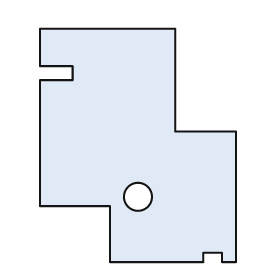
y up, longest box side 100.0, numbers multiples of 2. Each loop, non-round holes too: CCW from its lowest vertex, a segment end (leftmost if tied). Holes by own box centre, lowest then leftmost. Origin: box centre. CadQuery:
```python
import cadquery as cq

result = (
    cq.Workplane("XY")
    .moveTo(-12.0, -50.0)
    .lineTo(28.0, -50.0)
    .lineTo(28.0, -46.0)
    .lineTo(36.0, -46.0)
    .lineTo(36.0, -50.0)
    .lineTo(42.0, -50.0)
    .lineTo(42.0, 6.0)
    .lineTo(16.0, 6.0)
    .lineTo(16.0, 50.0)
    .lineTo(-42.0, 50.0)
    .lineTo(-42.0, 34.0)
    .lineTo(-28.0, 34.0)
    .lineTo(-28.0, 28.0)
    .lineTo(-42.0, 28.0)
    .lineTo(-42.0, -26.0)
    .lineTo(-12.0, -26.0)
    .close()
    .moveTo(0.0, -22.0)
    .circle(6.0)
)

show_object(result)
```